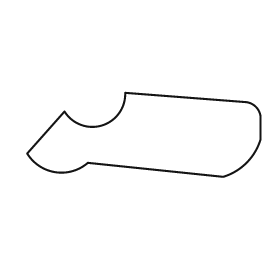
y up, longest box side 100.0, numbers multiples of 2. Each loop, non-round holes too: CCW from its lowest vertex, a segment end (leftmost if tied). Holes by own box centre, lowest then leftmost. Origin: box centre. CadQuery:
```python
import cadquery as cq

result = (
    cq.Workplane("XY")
    .moveTo(34.0, -18.0)
    .threePointArc((44.0, -12.0), (50.0, -2.0))
    .lineTo(50.0, 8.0)
    .threePointArc((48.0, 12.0), (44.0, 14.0))
    .lineTo(-8.0, 18.0)
    .threePointArc((-18.0, 4.0), (-34.0, 10.0))
    .lineTo(-50.0, -8.0)
    .threePointArc((-38.0, -16.0), (-24.0, -12.0))
    .close()
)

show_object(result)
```